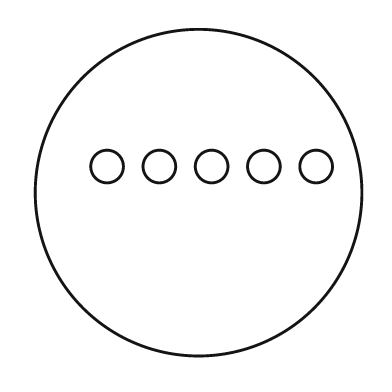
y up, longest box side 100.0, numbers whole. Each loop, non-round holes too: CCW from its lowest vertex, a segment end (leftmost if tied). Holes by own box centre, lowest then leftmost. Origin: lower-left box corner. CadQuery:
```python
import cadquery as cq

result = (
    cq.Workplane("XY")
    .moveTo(50.0, 50.0)
    .circle(50.0)
    .moveTo(22.0, 58.0)
    .circle(5.0)
    .moveTo(38.0, 58.0)
    .circle(5.0)
    .moveTo(54.0, 58.0)
    .circle(5.0)
    .moveTo(70.0, 58.0)
    .circle(5.0)
    .moveTo(86.0, 58.0)
    .circle(5.0)
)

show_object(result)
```